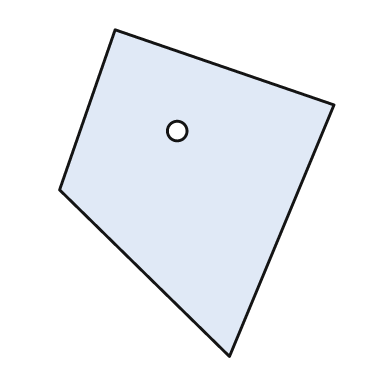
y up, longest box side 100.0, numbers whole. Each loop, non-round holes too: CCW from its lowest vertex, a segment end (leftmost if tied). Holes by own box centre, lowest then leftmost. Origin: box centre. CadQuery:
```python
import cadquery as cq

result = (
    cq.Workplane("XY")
    .moveTo(10.0, -50.0)
    .lineTo(42.0, 27.0)
    .lineTo(-25.0, 50.0)
    .lineTo(-42.0, 1.0)
    .close()
    .moveTo(-6.0, 19.0)
    .circle(3.0)
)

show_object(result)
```